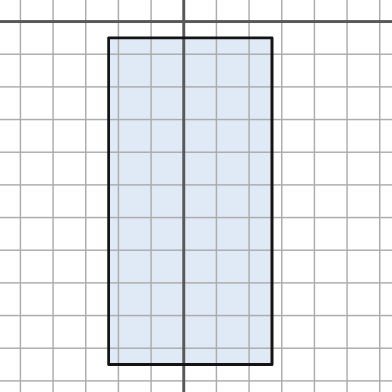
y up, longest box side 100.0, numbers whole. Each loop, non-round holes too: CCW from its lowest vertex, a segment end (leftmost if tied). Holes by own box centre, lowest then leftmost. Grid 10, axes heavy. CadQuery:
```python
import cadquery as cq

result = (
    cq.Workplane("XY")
    .moveTo(-23.0, -105.0)
    .lineTo(27.0, -105.0)
    .lineTo(27.0, -5.0)
    .lineTo(-23.0, -5.0)
    .close()
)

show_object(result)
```